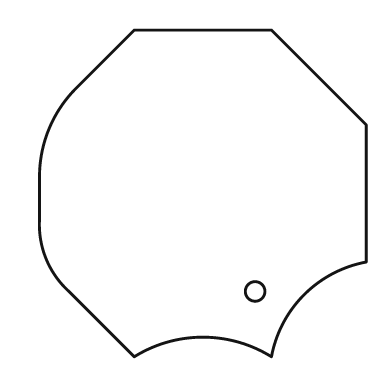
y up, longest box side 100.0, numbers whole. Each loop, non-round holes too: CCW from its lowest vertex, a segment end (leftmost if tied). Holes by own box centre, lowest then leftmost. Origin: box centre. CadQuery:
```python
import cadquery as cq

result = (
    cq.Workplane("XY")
    .moveTo(-21.0, -50.0)
    .threePointArc((0.0, -44.0), (21.0, -50.0))
    .threePointArc((31.0, -31.0), (50.0, -21.0))
    .lineTo(50.0, 21.0)
    .lineTo(21.0, 50.0)
    .lineTo(-21.0, 50.0)
    .lineTo(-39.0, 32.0)
    .threePointArc((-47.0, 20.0), (-50.0, 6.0))
    .lineTo(-50.0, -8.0)
    .threePointArc((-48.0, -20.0), (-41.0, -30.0))
    .close()
    .moveTo(16.0, -30.0)
    .circle(3.0)
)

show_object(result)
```